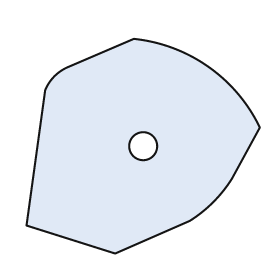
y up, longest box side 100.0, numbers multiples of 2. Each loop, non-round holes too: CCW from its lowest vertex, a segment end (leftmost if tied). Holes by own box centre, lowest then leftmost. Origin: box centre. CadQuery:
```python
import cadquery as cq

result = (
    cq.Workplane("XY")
    .moveTo(-12.0, -46.0)
    .lineTo(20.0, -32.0)
    .threePointArc((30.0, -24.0), (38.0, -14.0))
    .lineTo(50.0, 8.0)
    .threePointArc((28.0, 34.0), (-4.0, 46.0))
    .lineTo(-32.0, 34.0)
    .threePointArc((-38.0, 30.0), (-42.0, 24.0))
    .lineTo(-50.0, -34.0)
    .close()
    .moveTo(0.0, 0.0)
    .circle(6.0)
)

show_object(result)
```